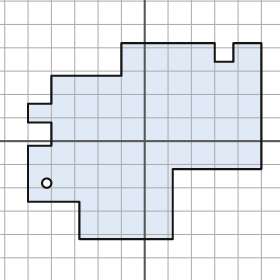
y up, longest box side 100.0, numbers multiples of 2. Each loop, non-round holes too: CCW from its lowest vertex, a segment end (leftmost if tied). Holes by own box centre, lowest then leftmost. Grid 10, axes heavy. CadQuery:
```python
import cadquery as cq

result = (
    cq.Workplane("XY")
    .moveTo(-28.0, -42.0)
    .lineTo(12.0, -42.0)
    .lineTo(12.0, -12.0)
    .lineTo(50.0, -12.0)
    .lineTo(50.0, 42.0)
    .lineTo(38.0, 42.0)
    .lineTo(38.0, 34.0)
    .lineTo(30.0, 34.0)
    .lineTo(30.0, 42.0)
    .lineTo(-10.0, 42.0)
    .lineTo(-10.0, 28.0)
    .lineTo(-40.0, 28.0)
    .lineTo(-40.0, 16.0)
    .lineTo(-50.0, 16.0)
    .lineTo(-50.0, 8.0)
    .lineTo(-40.0, 8.0)
    .lineTo(-40.0, -2.0)
    .lineTo(-50.0, -2.0)
    .lineTo(-50.0, -26.0)
    .lineTo(-28.0, -26.0)
    .close()
    .moveTo(-42.0, -18.0)
    .circle(2.0)
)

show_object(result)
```